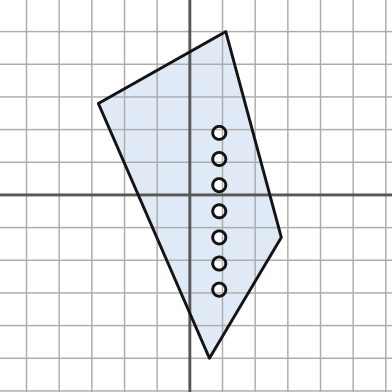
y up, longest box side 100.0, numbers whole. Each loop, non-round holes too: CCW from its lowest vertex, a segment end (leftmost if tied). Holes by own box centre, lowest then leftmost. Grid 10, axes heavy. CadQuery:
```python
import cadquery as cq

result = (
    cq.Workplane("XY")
    .moveTo(6.0, -50.0)
    .lineTo(28.0, -13.0)
    .lineTo(11.0, 50.0)
    .lineTo(-28.0, 28.0)
    .close()
    .moveTo(9.0, -29.0)
    .circle(2.0)
    .moveTo(9.0, -21.0)
    .circle(2.0)
    .moveTo(9.0, -13.0)
    .circle(2.0)
    .moveTo(9.0, -5.0)
    .circle(2.0)
    .moveTo(9.0, 3.0)
    .circle(2.0)
    .moveTo(9.0, 11.0)
    .circle(2.0)
    .moveTo(9.0, 19.0)
    .circle(2.0)
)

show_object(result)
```